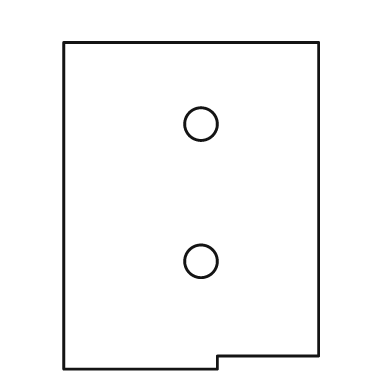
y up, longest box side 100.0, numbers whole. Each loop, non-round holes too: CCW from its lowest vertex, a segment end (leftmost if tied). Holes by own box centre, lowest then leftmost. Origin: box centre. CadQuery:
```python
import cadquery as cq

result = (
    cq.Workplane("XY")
    .moveTo(-39.0, -50.0)
    .lineTo(8.0, -50.0)
    .lineTo(8.0, -46.0)
    .lineTo(39.0, -46.0)
    .lineTo(39.0, 50.0)
    .lineTo(-39.0, 50.0)
    .close()
    .moveTo(3.0, -17.0)
    .circle(5.0)
    .moveTo(3.0, 25.0)
    .circle(5.0)
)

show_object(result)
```